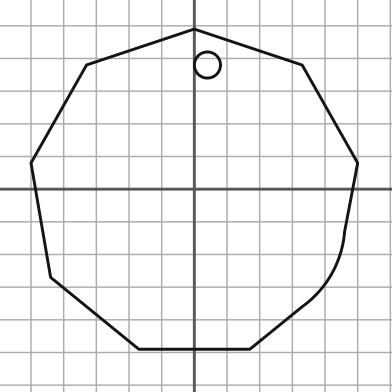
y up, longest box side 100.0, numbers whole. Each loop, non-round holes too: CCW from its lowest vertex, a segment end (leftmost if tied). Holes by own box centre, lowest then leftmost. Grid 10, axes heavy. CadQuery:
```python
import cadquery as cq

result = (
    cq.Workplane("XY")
    .moveTo(-17.0, -49.0)
    .lineTo(17.0, -49.0)
    .lineTo(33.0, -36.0)
    .threePointArc((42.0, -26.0), (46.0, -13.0))
    .lineTo(50.0, 8.0)
    .lineTo(33.0, 38.0)
    .lineTo(0.0, 49.0)
    .lineTo(-33.0, 38.0)
    .lineTo(-50.0, 8.0)
    .lineTo(-44.0, -27.0)
    .close()
    .moveTo(4.0, 38.0)
    .circle(4.0)
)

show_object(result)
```